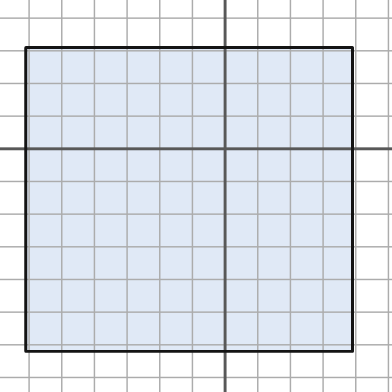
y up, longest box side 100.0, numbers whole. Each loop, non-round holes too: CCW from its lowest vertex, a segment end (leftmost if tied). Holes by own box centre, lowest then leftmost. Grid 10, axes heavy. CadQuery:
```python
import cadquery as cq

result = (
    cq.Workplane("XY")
    .moveTo(-61.0, -62.0)
    .lineTo(39.0, -62.0)
    .lineTo(39.0, 31.0)
    .lineTo(-61.0, 31.0)
    .close()
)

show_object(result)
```